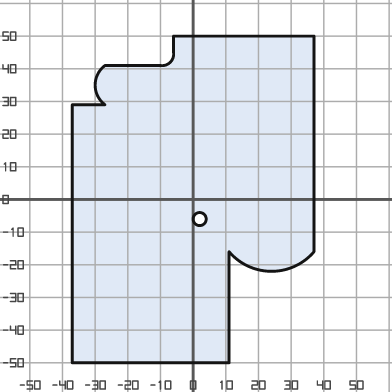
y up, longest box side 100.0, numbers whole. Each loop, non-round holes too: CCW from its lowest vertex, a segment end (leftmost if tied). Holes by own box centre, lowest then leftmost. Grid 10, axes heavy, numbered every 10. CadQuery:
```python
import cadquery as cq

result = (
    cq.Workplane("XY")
    .moveTo(-37.0, -50.0)
    .lineTo(11.0, -50.0)
    .lineTo(11.0, -16.0)
    .threePointArc((24.0, -22.0), (37.0, -16.0))
    .lineTo(37.0, 50.0)
    .lineTo(-6.0, 50.0)
    .lineTo(-6.0, 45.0)
    .threePointArc((-7.0, 42.0), (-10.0, 41.0))
    .lineTo(-27.0, 41.0)
    .threePointArc((-30.0, 35.0), (-27.0, 29.0))
    .lineTo(-37.0, 29.0)
    .close()
    .moveTo(2.0, -6.0)
    .circle(2.0)
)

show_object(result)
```